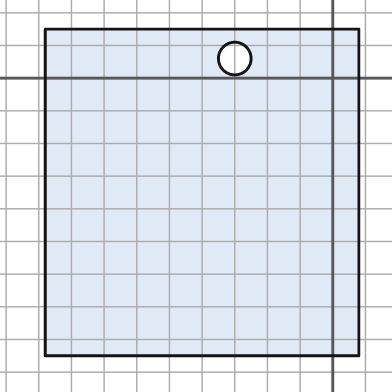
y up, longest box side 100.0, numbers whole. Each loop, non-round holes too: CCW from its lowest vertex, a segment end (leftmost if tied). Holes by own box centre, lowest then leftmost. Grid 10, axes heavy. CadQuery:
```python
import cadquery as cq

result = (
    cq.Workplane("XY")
    .moveTo(-88.0, -85.0)
    .lineTo(8.0, -85.0)
    .lineTo(8.0, 15.0)
    .lineTo(-88.0, 15.0)
    .close()
    .moveTo(-30.0, 6.0)
    .circle(5.0)
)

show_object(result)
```